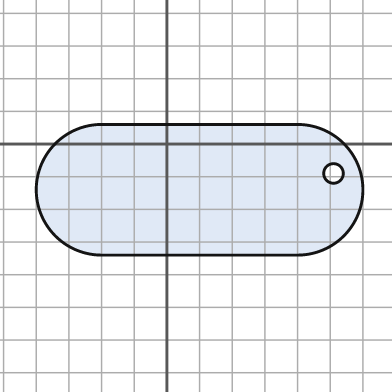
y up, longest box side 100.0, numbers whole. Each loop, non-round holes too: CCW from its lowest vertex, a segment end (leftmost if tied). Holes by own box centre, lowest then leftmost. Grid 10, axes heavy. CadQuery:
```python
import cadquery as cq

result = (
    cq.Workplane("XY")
    .moveTo(-20.0, -34.0)
    .lineTo(40.0, -34.0)
    .threePointArc((60.0, -14.0), (40.0, 6.0))
    .lineTo(-20.0, 6.0)
    .threePointArc((-40.0, -14.0), (-20.0, -34.0))
    .close()
    .moveTo(51.0, -9.0)
    .circle(3.0)
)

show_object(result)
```